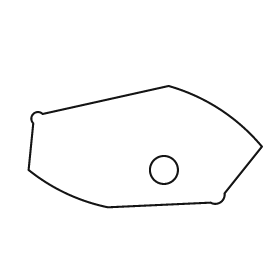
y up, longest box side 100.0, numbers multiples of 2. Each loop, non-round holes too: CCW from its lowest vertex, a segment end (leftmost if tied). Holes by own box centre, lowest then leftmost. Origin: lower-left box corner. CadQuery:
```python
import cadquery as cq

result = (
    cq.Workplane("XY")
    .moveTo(34.0, 0.0)
    .lineTo(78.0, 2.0)
    .threePointArc((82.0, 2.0), (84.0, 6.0))
    .lineTo(100.0, 26.0)
    .threePointArc((82.0, 42.0), (60.0, 52.0))
    .lineTo(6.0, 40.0)
    .threePointArc((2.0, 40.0), (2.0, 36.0))
    .lineTo(0.0, 16.0)
    .threePointArc((16.0, 6.0), (34.0, 0.0))
    .close()
    .moveTo(58.0, 16.0)
    .circle(6.0)
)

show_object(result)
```